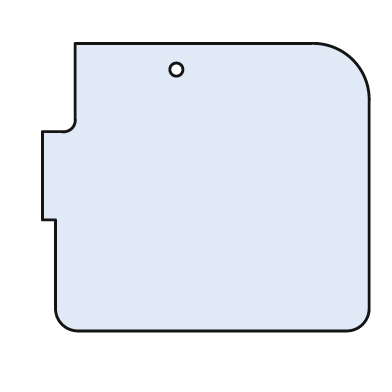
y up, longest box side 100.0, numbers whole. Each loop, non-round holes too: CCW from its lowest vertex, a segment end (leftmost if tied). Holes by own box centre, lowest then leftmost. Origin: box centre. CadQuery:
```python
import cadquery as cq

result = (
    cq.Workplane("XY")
    .moveTo(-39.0, -44.0)
    .lineTo(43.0, -44.0)
    .threePointArc((48.0, -42.0), (50.0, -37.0))
    .lineTo(50.0, 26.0)
    .threePointArc((45.0, 39.0), (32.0, 44.0))
    .lineTo(-40.0, 44.0)
    .lineTo(-40.0, 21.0)
    .threePointArc((-41.0, 18.0), (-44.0, 17.0))
    .lineTo(-50.0, 17.0)
    .lineTo(-50.0, -10.0)
    .lineTo(-46.0, -10.0)
    .lineTo(-46.0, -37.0)
    .threePointArc((-44.0, -42.0), (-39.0, -44.0))
    .close()
    .moveTo(-9.0, 36.0)
    .circle(2.0)
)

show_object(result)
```